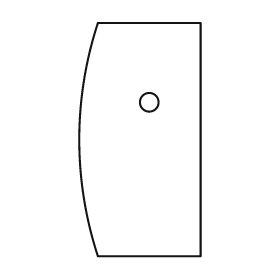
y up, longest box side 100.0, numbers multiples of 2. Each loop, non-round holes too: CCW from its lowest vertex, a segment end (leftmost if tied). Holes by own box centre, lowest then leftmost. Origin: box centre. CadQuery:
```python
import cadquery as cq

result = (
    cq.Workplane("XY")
    .moveTo(-18.0, -50.0)
    .lineTo(26.0, -50.0)
    .lineTo(26.0, 50.0)
    .lineTo(-18.0, 50.0)
    .threePointArc((-26.0, 0.0), (-18.0, -50.0))
    .close()
    .moveTo(4.0, 16.0)
    .circle(4.0)
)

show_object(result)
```